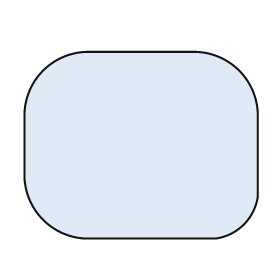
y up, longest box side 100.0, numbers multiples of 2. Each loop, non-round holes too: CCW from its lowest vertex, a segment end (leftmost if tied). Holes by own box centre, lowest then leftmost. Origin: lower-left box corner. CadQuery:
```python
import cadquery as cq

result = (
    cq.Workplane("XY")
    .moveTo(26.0, 0.0)
    .lineTo(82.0, 0.0)
    .threePointArc((94.0, 6.0), (100.0, 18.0))
    .lineTo(100.0, 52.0)
    .threePointArc((92.0, 72.0), (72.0, 80.0))
    .lineTo(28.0, 80.0)
    .threePointArc((8.0, 72.0), (0.0, 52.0))
    .lineTo(0.0, 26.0)
    .threePointArc((8.0, 8.0), (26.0, 0.0))
    .close()
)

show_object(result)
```